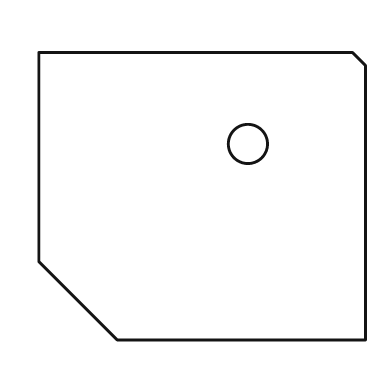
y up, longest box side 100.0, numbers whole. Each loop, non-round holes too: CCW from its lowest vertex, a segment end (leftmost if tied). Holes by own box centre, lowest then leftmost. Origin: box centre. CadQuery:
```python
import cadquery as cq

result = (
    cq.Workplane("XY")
    .moveTo(-26.0, -44.0)
    .lineTo(50.0, -44.0)
    .lineTo(50.0, 40.0)
    .lineTo(46.0, 44.0)
    .lineTo(-50.0, 44.0)
    .lineTo(-50.0, -20.0)
    .close()
    .moveTo(14.0, 16.0)
    .circle(6.0)
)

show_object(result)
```